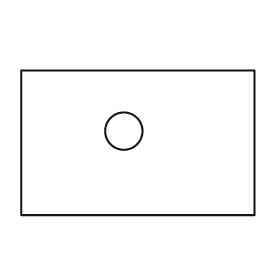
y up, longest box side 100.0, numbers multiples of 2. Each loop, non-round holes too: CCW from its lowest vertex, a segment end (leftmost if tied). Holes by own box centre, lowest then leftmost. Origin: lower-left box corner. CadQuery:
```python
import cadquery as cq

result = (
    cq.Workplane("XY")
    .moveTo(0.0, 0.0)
    .lineTo(100.0, 0.0)
    .lineTo(100.0, 62.0)
    .lineTo(0.0, 62.0)
    .close()
    .moveTo(44.0, 36.0)
    .circle(8.0)
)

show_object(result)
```